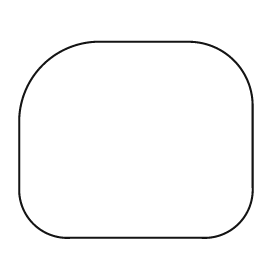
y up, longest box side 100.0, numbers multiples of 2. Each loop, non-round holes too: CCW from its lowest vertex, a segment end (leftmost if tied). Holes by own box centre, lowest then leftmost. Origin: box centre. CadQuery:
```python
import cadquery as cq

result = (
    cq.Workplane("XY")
    .moveTo(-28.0, -42.0)
    .lineTo(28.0, -42.0)
    .threePointArc((44.0, -36.0), (50.0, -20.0))
    .lineTo(50.0, 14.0)
    .threePointArc((42.0, 34.0), (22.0, 42.0))
    .lineTo(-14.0, 42.0)
    .threePointArc((-40.0, 32.0), (-50.0, 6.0))
    .lineTo(-50.0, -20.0)
    .threePointArc((-44.0, -36.0), (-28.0, -42.0))
    .close()
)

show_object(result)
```